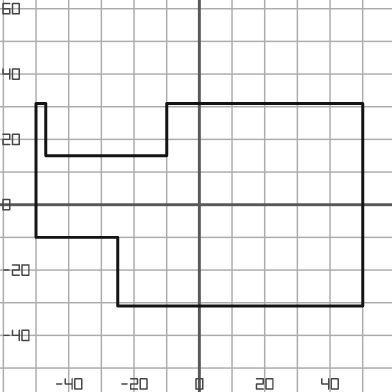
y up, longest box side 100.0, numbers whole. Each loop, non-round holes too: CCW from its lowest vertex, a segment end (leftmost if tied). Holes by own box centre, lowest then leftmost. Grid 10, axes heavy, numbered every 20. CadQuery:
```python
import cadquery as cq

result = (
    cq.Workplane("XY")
    .moveTo(-25.0, -31.0)
    .lineTo(50.0, -31.0)
    .lineTo(50.0, 31.0)
    .lineTo(-10.0, 31.0)
    .lineTo(-10.0, 15.0)
    .lineTo(-47.0, 15.0)
    .lineTo(-47.0, 31.0)
    .lineTo(-50.0, 31.0)
    .lineTo(-50.0, -10.0)
    .lineTo(-25.0, -10.0)
    .close()
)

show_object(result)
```